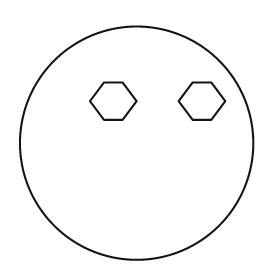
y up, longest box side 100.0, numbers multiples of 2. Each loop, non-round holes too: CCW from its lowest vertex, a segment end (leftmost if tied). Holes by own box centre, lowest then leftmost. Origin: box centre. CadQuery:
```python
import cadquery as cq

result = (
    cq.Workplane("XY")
    .moveTo(0.0, 0.0)
    .circle(50.0)
    .moveTo(-14.0, 10.0)
    .lineTo(-6.0, 10.0)
    .lineTo(0.0, 18.0)
    .lineTo(-6.0, 26.0)
    .lineTo(-14.0, 26.0)
    .lineTo(-20.0, 18.0)
    .close()
    .moveTo(24.0, 10.0)
    .lineTo(32.0, 10.0)
    .lineTo(38.0, 18.0)
    .lineTo(32.0, 26.0)
    .lineTo(24.0, 26.0)
    .lineTo(18.0, 18.0)
    .close()
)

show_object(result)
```